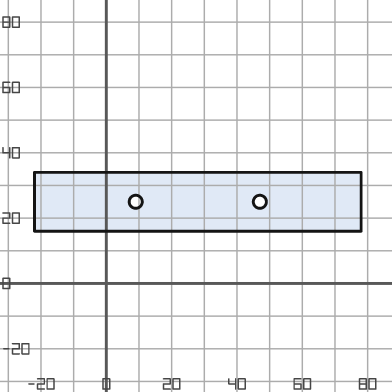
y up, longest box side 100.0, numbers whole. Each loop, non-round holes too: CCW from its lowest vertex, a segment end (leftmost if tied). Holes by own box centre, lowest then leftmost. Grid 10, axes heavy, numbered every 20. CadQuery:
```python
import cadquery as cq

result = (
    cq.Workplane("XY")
    .moveTo(-22.0, 16.0)
    .lineTo(78.0, 16.0)
    .lineTo(78.0, 34.0)
    .lineTo(-22.0, 34.0)
    .close()
    .moveTo(9.0, 25.0)
    .circle(2.0)
    .moveTo(47.0, 25.0)
    .circle(2.0)
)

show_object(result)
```